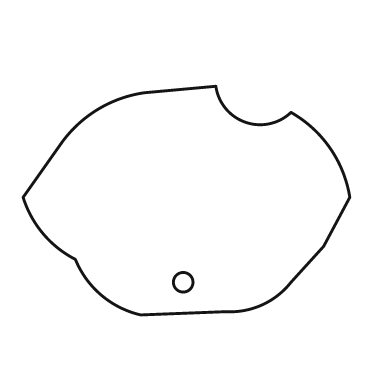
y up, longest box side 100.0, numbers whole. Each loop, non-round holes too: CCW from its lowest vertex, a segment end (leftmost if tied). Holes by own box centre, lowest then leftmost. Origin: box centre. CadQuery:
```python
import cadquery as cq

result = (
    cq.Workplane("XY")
    .moveTo(-14.0, -35.0)
    .lineTo(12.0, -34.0)
    .threePointArc((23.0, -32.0), (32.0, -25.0))
    .lineTo(42.0, -14.0)
    .lineTo(50.0, 1.0)
    .threePointArc((44.0, 16.0), (32.0, 27.0))
    .threePointArc((18.0, 24.0), (9.0, 35.0))
    .lineTo(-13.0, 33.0)
    .threePointArc((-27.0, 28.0), (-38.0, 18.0))
    .lineTo(-50.0, 1.0)
    .threePointArc((-44.0, -10.0), (-34.0, -18.0))
    .threePointArc((-26.0, -29.0), (-14.0, -35.0))
    .close()
    .moveTo(-1.0, -25.0)
    .circle(3.0)
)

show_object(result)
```